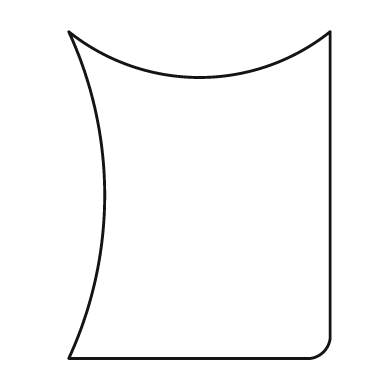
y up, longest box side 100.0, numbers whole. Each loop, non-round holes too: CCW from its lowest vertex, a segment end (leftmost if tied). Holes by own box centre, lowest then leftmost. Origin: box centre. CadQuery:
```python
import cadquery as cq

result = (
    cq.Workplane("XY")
    .moveTo(-40.0, -50.0)
    .lineTo(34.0, -50.0)
    .threePointArc((38.0, -48.0), (40.0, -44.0))
    .lineTo(40.0, 50.0)
    .threePointArc((0.0, 36.0), (-40.0, 50.0))
    .threePointArc((-29.0, 0.0), (-40.0, -50.0))
    .close()
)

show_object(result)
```